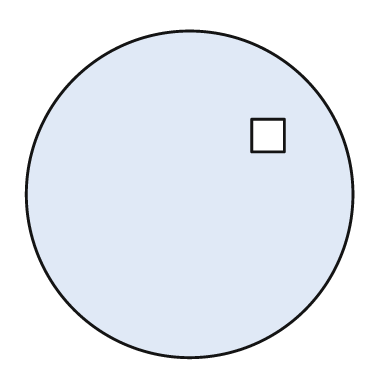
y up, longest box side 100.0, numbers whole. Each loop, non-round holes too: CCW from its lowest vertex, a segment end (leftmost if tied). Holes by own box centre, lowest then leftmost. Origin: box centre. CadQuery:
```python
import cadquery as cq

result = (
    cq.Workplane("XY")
    .moveTo(0.0, 0.0)
    .circle(50.0)
    .moveTo(19.0, 13.0)
    .lineTo(29.0, 13.0)
    .lineTo(29.0, 23.0)
    .lineTo(19.0, 23.0)
    .close()
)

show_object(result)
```